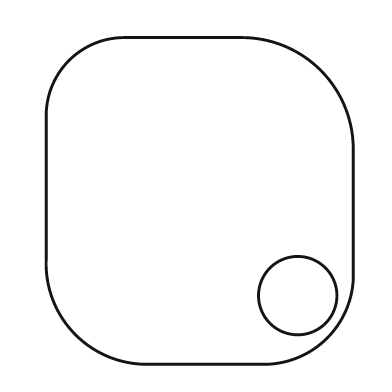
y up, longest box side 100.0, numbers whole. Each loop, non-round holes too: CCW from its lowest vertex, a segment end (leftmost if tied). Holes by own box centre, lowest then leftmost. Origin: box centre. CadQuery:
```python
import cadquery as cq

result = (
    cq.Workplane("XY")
    .moveTo(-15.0, -50.0)
    .lineTo(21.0, -50.0)
    .threePointArc((39.0, -42.0), (47.0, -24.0))
    .lineTo(47.0, 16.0)
    .threePointArc((37.0, 40.0), (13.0, 50.0))
    .lineTo(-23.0, 50.0)
    .threePointArc((-40.0, 43.0), (-47.0, 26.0))
    .lineTo(-47.0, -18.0)
    .threePointArc((-38.0, -41.0), (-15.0, -50.0))
    .close()
    .moveTo(30.0, -29.0)
    .circle(12.0)
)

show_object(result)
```